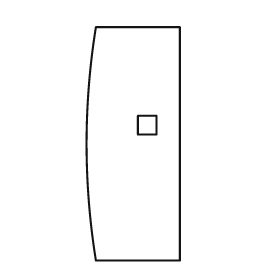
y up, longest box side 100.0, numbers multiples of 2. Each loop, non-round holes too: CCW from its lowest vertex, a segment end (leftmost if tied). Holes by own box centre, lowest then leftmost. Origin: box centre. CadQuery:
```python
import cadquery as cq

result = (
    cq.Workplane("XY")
    .moveTo(-16.0, -50.0)
    .lineTo(20.0, -50.0)
    .lineTo(20.0, 50.0)
    .lineTo(-16.0, 50.0)
    .threePointArc((-20.0, 0.0), (-16.0, -50.0))
    .close()
    .moveTo(2.0, 4.0)
    .lineTo(10.0, 4.0)
    .lineTo(10.0, 12.0)
    .lineTo(2.0, 12.0)
    .close()
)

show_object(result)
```